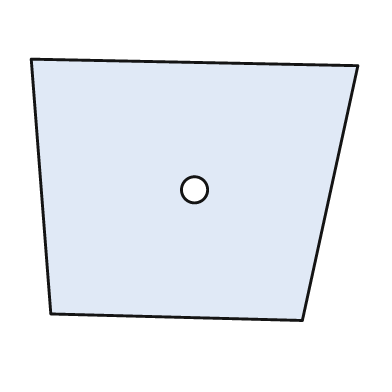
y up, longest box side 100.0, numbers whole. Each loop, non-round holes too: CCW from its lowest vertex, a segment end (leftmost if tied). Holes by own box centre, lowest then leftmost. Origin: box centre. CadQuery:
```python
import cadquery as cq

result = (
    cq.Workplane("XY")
    .moveTo(33.0, -40.0)
    .lineTo(50.0, 38.0)
    .lineTo(-50.0, 40.0)
    .lineTo(-44.0, -38.0)
    .close()
    .moveTo(0.0, 0.0)
    .circle(4.0)
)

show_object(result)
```